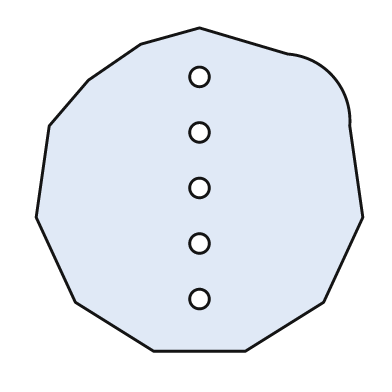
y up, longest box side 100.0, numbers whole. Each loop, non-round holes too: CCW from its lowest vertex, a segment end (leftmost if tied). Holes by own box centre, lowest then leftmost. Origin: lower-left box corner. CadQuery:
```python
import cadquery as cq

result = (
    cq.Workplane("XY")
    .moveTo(36.0, 0.0)
    .lineTo(64.0, 0.0)
    .lineTo(88.0, 15.0)
    .lineTo(100.0, 41.0)
    .lineTo(96.0, 69.0)
    .threePointArc((91.0, 84.0), (77.0, 91.0))
    .lineTo(50.0, 99.0)
    .lineTo(32.0, 94.0)
    .lineTo(16.0, 83.0)
    .lineTo(4.0, 69.0)
    .lineTo(0.0, 41.0)
    .lineTo(12.0, 15.0)
    .close()
    .moveTo(50.0, 16.0)
    .circle(3.0)
    .moveTo(50.0, 33.0)
    .circle(3.0)
    .moveTo(50.0, 50.0)
    .circle(3.0)
    .moveTo(50.0, 67.0)
    .circle(3.0)
    .moveTo(50.0, 84.0)
    .circle(3.0)
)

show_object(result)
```